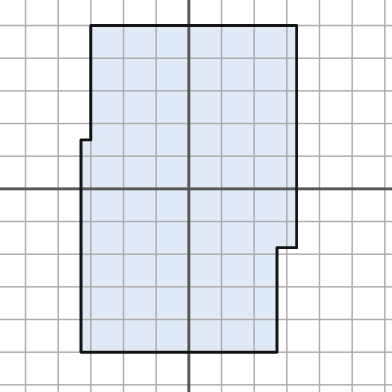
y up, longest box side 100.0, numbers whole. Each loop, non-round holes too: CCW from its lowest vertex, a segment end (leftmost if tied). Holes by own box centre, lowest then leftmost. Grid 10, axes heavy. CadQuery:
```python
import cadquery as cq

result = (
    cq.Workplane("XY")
    .moveTo(-33.0, -50.0)
    .lineTo(27.0, -50.0)
    .lineTo(27.0, -18.0)
    .lineTo(33.0, -18.0)
    .lineTo(33.0, 50.0)
    .lineTo(-30.0, 50.0)
    .lineTo(-30.0, 15.0)
    .lineTo(-33.0, 15.0)
    .close()
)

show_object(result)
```